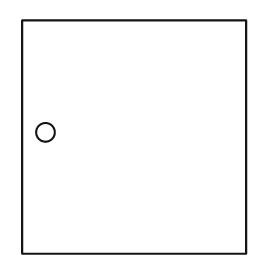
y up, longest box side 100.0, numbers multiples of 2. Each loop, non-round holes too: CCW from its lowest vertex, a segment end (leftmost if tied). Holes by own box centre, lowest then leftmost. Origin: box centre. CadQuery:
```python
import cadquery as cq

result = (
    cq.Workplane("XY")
    .moveTo(-48.0, -50.0)
    .lineTo(48.0, -50.0)
    .lineTo(48.0, 50.0)
    .lineTo(-48.0, 50.0)
    .close()
    .moveTo(-38.0, 2.0)
    .circle(4.0)
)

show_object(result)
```